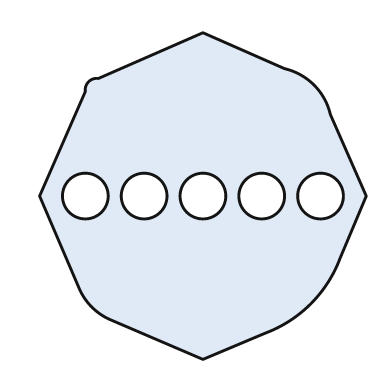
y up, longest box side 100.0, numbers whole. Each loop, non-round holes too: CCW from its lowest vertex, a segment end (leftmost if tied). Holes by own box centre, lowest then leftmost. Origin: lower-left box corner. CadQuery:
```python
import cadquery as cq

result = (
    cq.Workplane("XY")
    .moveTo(50.0, 0.0)
    .lineTo(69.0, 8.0)
    .threePointArc((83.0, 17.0), (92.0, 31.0))
    .lineTo(100.0, 50.0)
    .lineTo(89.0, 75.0)
    .threePointArc((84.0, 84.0), (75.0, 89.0))
    .lineTo(50.0, 100.0)
    .lineTo(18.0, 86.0)
    .threePointArc((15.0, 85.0), (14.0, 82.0))
    .lineTo(0.0, 50.0)
    .lineTo(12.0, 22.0)
    .threePointArc((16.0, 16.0), (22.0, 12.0))
    .close()
    .moveTo(14.0, 50.0)
    .circle(7.0)
    .moveTo(32.0, 50.0)
    .circle(7.0)
    .moveTo(50.0, 50.0)
    .circle(7.0)
    .moveTo(68.0, 50.0)
    .circle(7.0)
    .moveTo(86.0, 50.0)
    .circle(7.0)
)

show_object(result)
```